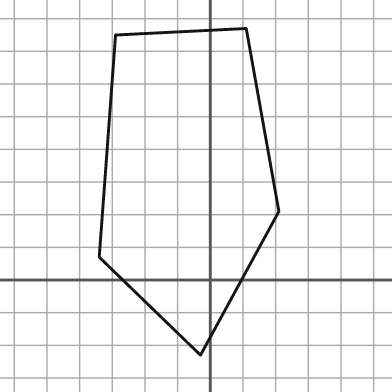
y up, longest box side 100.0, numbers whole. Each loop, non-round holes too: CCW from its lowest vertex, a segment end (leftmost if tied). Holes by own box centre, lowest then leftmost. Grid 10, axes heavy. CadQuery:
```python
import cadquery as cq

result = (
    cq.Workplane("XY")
    .moveTo(-3.0, -23.0)
    .lineTo(21.0, 21.0)
    .lineTo(11.0, 77.0)
    .lineTo(-29.0, 75.0)
    .lineTo(-34.0, 7.0)
    .close()
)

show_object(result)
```